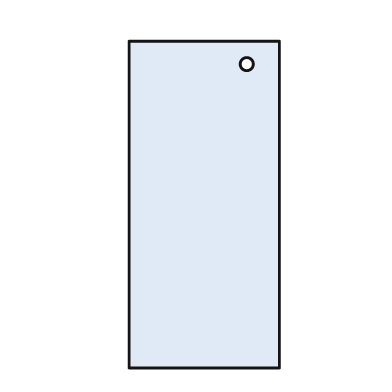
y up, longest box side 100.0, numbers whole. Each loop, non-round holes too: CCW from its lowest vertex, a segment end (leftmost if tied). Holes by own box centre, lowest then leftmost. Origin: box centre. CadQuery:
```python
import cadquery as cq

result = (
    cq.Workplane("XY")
    .moveTo(-23.0, -50.0)
    .lineTo(23.0, -50.0)
    .lineTo(23.0, 50.0)
    .lineTo(-23.0, 50.0)
    .close()
    .moveTo(13.0, 43.0)
    .circle(2.0)
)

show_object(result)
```